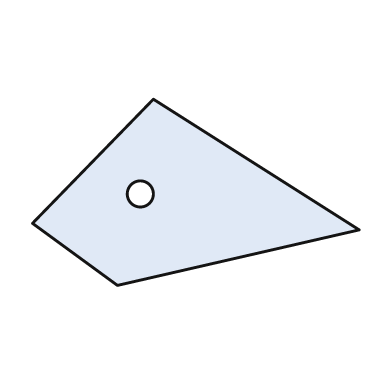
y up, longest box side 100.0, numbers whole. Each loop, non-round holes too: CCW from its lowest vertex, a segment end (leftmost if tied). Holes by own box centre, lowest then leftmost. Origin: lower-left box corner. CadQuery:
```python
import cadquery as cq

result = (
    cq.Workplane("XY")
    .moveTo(26.0, 0.0)
    .lineTo(100.0, 17.0)
    .lineTo(37.0, 57.0)
    .lineTo(0.0, 19.0)
    .close()
    .moveTo(33.0, 28.0)
    .circle(4.0)
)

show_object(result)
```